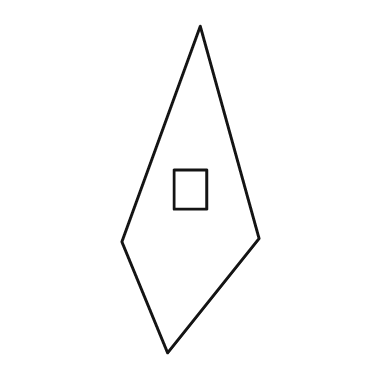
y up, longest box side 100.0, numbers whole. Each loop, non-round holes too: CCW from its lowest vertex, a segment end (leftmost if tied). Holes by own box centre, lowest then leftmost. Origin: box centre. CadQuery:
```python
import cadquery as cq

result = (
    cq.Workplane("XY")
    .moveTo(-7.0, -50.0)
    .lineTo(21.0, -15.0)
    .lineTo(3.0, 50.0)
    .lineTo(-21.0, -16.0)
    .close()
    .moveTo(-5.0, -6.0)
    .lineTo(5.0, -6.0)
    .lineTo(5.0, 6.0)
    .lineTo(-5.0, 6.0)
    .close()
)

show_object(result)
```